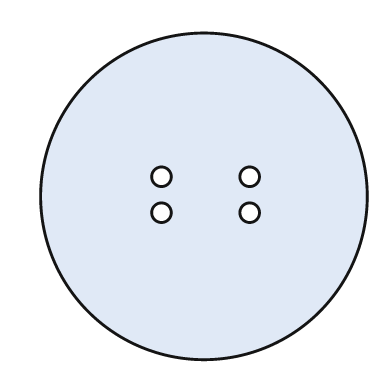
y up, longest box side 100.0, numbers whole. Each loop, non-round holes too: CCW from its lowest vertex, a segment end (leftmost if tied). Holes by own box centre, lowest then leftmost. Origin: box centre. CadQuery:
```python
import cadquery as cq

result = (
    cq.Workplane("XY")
    .moveTo(0.0, 0.0)
    .circle(50.0)
    .moveTo(-13.0, -5.0)
    .circle(3.0)
    .moveTo(14.0, -5.0)
    .circle(3.0)
    .moveTo(-13.0, 6.0)
    .circle(3.0)
    .moveTo(14.0, 6.0)
    .circle(3.0)
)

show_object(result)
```